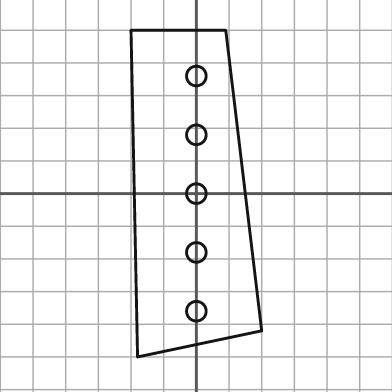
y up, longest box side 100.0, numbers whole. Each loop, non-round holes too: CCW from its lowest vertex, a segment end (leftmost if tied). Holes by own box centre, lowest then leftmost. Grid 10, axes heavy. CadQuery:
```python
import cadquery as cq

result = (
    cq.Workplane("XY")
    .moveTo(-18.0, -50.0)
    .lineTo(20.0, -42.0)
    .lineTo(9.0, 50.0)
    .lineTo(-20.0, 50.0)
    .close()
    .moveTo(0.0, -36.0)
    .circle(3.0)
    .moveTo(0.0, -18.0)
    .circle(3.0)
    .moveTo(0.0, 0.0)
    .circle(3.0)
    .moveTo(0.0, 18.0)
    .circle(3.0)
    .moveTo(0.0, 36.0)
    .circle(3.0)
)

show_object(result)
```